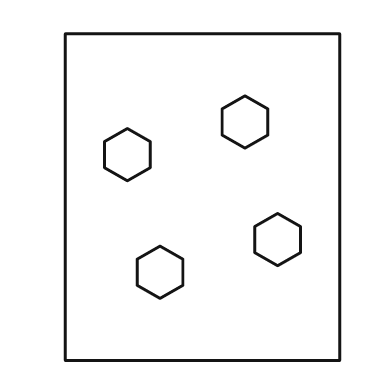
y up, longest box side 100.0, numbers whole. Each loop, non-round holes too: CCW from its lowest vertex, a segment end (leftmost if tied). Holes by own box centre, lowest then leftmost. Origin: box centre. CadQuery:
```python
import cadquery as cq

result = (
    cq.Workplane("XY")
    .moveTo(-42.0, -50.0)
    .lineTo(42.0, -50.0)
    .lineTo(42.0, 50.0)
    .lineTo(-42.0, 50.0)
    .close()
    .moveTo(-13.0, -31.0)
    .lineTo(-6.0, -27.0)
    .lineTo(-6.0, -19.0)
    .lineTo(-13.0, -15.0)
    .lineTo(-20.0, -19.0)
    .lineTo(-20.0, -27.0)
    .close()
    .moveTo(23.0, -21.0)
    .lineTo(30.0, -17.0)
    .lineTo(30.0, -9.0)
    .lineTo(23.0, -5.0)
    .lineTo(16.0, -9.0)
    .lineTo(16.0, -17.0)
    .close()
    .moveTo(-23.0, 5.0)
    .lineTo(-16.0, 9.0)
    .lineTo(-16.0, 17.0)
    .lineTo(-23.0, 21.0)
    .lineTo(-30.0, 17.0)
    .lineTo(-30.0, 9.0)
    .close()
    .moveTo(13.0, 15.0)
    .lineTo(20.0, 19.0)
    .lineTo(20.0, 27.0)
    .lineTo(13.0, 31.0)
    .lineTo(6.0, 27.0)
    .lineTo(6.0, 19.0)
    .close()
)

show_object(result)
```